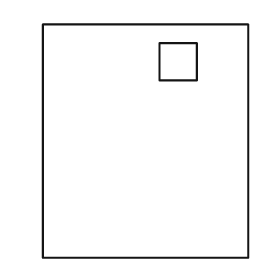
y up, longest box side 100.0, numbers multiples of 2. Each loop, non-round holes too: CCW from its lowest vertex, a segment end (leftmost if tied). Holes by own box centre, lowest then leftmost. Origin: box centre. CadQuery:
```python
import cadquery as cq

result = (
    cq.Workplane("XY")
    .moveTo(-44.0, -50.0)
    .lineTo(44.0, -50.0)
    .lineTo(44.0, 50.0)
    .lineTo(-44.0, 50.0)
    .close()
    .moveTo(6.0, 26.0)
    .lineTo(22.0, 26.0)
    .lineTo(22.0, 42.0)
    .lineTo(6.0, 42.0)
    .close()
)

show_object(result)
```